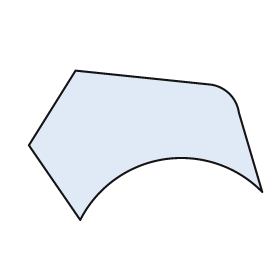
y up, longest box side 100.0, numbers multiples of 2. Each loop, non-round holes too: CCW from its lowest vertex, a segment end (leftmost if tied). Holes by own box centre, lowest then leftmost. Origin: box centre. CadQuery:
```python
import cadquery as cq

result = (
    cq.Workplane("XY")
    .moveTo(-28.0, -32.0)
    .threePointArc((8.0, -6.0), (50.0, -20.0))
    .lineTo(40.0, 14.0)
    .threePointArc((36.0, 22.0), (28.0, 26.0))
    .lineTo(-30.0, 32.0)
    .lineTo(-50.0, 0.0)
    .close()
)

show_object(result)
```